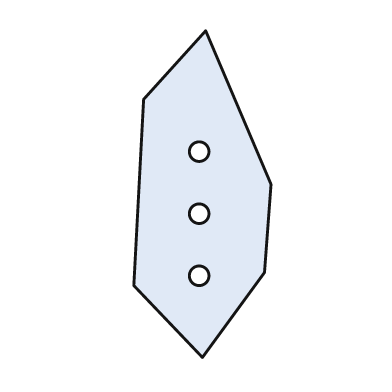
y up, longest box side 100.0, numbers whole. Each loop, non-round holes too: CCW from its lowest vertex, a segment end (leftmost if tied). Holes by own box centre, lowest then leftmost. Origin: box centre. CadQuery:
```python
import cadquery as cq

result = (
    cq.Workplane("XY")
    .moveTo(0.0, -50.0)
    .lineTo(19.0, -24.0)
    .lineTo(21.0, 3.0)
    .lineTo(1.0, 50.0)
    .lineTo(-18.0, 29.0)
    .lineTo(-21.0, -28.0)
    .close()
    .moveTo(-1.0, -25.0)
    .circle(3.0)
    .moveTo(-1.0, -6.0)
    .circle(3.0)
    .moveTo(-1.0, 13.0)
    .circle(3.0)
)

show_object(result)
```